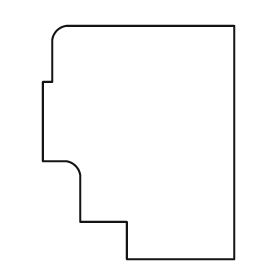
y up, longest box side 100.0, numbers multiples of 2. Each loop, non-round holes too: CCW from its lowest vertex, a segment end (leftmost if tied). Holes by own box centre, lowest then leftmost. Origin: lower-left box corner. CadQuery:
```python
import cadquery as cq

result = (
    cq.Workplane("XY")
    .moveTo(36.0, 0.0)
    .lineTo(82.0, 0.0)
    .lineTo(82.0, 100.0)
    .lineTo(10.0, 100.0)
    .threePointArc((6.0, 98.0), (4.0, 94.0))
    .lineTo(4.0, 76.0)
    .lineTo(0.0, 76.0)
    .lineTo(0.0, 42.0)
    .lineTo(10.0, 42.0)
    .threePointArc((14.0, 40.0), (16.0, 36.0))
    .lineTo(16.0, 16.0)
    .lineTo(36.0, 16.0)
    .close()
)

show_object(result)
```